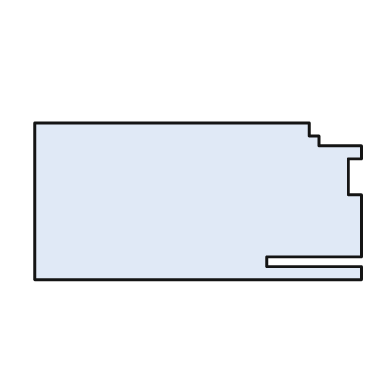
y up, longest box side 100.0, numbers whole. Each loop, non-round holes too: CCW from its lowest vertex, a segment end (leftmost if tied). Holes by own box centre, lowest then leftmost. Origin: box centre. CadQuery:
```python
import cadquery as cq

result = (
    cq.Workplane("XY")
    .moveTo(-50.0, -24.0)
    .lineTo(50.0, -24.0)
    .lineTo(50.0, -20.0)
    .lineTo(21.0, -20.0)
    .lineTo(21.0, -17.0)
    .lineTo(50.0, -17.0)
    .lineTo(50.0, 2.0)
    .lineTo(46.0, 2.0)
    .lineTo(46.0, 13.0)
    .lineTo(50.0, 13.0)
    .lineTo(50.0, 17.0)
    .lineTo(37.0, 17.0)
    .lineTo(37.0, 20.0)
    .lineTo(34.0, 20.0)
    .lineTo(34.0, 24.0)
    .lineTo(-50.0, 24.0)
    .close()
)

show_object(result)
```